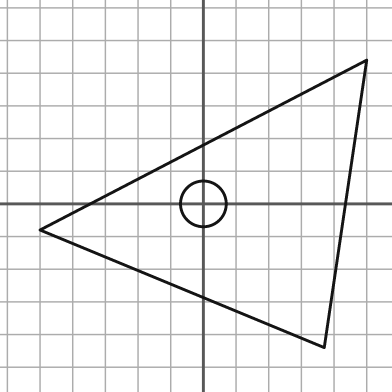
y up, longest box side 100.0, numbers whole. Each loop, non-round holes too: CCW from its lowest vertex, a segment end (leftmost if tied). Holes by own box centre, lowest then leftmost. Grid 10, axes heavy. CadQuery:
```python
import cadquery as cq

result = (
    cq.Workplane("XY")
    .moveTo(37.0, -44.0)
    .lineTo(50.0, 44.0)
    .lineTo(-50.0, -8.0)
    .close()
    .moveTo(0.0, 0.0)
    .circle(7.0)
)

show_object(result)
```